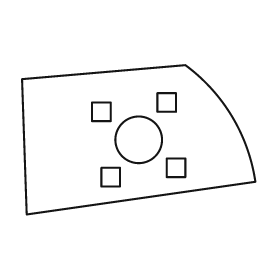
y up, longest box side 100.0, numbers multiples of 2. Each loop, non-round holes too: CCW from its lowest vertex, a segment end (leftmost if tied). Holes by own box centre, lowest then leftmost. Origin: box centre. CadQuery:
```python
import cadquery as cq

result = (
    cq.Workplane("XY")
    .moveTo(-48.0, -32.0)
    .lineTo(50.0, -18.0)
    .threePointArc((40.0, 10.0), (20.0, 32.0))
    .lineTo(-50.0, 26.0)
    .close()
    .moveTo(-16.0, -20.0)
    .lineTo(-8.0, -20.0)
    .lineTo(-8.0, -12.0)
    .lineTo(-16.0, -12.0)
    .close()
    .moveTo(12.0, -16.0)
    .lineTo(20.0, -16.0)
    .lineTo(20.0, -8.0)
    .lineTo(12.0, -8.0)
    .close()
    .moveTo(0.0, 0.0)
    .circle(10.0)
    .moveTo(-20.0, 8.0)
    .lineTo(-12.0, 8.0)
    .lineTo(-12.0, 16.0)
    .lineTo(-20.0, 16.0)
    .close()
    .moveTo(8.0, 12.0)
    .lineTo(16.0, 12.0)
    .lineTo(16.0, 20.0)
    .lineTo(8.0, 20.0)
    .close()
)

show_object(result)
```